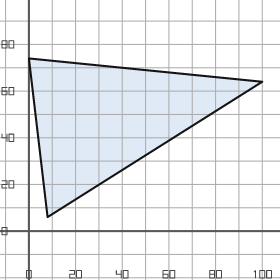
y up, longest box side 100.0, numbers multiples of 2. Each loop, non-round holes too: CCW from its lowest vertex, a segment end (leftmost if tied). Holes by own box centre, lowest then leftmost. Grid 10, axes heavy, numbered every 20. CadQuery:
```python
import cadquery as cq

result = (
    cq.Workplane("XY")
    .moveTo(8.0, 6.0)
    .lineTo(100.0, 64.0)
    .lineTo(0.0, 74.0)
    .close()
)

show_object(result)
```